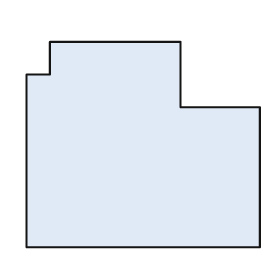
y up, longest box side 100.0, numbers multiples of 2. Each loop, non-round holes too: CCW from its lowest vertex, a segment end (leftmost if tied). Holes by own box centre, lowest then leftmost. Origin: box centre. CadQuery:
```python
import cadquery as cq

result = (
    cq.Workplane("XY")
    .moveTo(-50.0, -44.0)
    .lineTo(50.0, -44.0)
    .lineTo(50.0, 16.0)
    .lineTo(16.0, 16.0)
    .lineTo(16.0, 44.0)
    .lineTo(-40.0, 44.0)
    .lineTo(-40.0, 30.0)
    .lineTo(-50.0, 30.0)
    .close()
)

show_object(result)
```